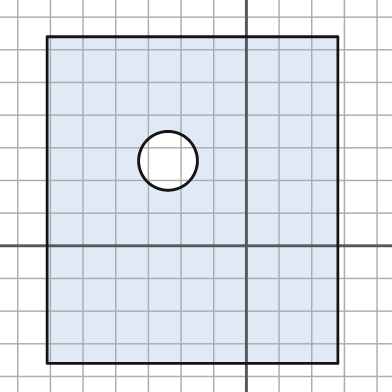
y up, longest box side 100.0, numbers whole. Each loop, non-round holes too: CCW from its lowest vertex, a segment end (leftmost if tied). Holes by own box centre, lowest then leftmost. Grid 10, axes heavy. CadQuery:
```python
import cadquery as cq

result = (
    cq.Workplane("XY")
    .moveTo(-61.0, -36.0)
    .lineTo(28.0, -36.0)
    .lineTo(28.0, 64.0)
    .lineTo(-61.0, 64.0)
    .close()
    .moveTo(-24.0, 26.0)
    .circle(9.0)
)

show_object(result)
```